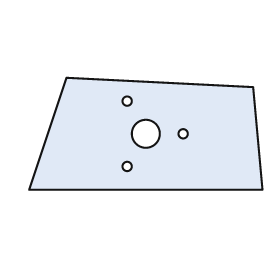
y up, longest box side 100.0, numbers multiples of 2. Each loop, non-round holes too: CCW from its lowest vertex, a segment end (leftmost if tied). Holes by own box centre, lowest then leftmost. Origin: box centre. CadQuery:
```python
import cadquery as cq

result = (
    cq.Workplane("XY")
    .moveTo(-50.0, -24.0)
    .lineTo(50.0, -24.0)
    .lineTo(46.0, 20.0)
    .lineTo(-34.0, 24.0)
    .close()
    .moveTo(-8.0, -14.0)
    .circle(2.0)
    .moveTo(0.0, 0.0)
    .circle(6.0)
    .moveTo(16.0, 0.0)
    .circle(2.0)
    .moveTo(-8.0, 14.0)
    .circle(2.0)
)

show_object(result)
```